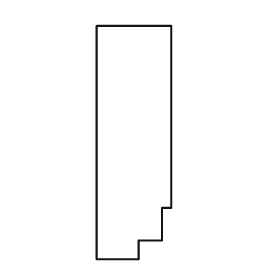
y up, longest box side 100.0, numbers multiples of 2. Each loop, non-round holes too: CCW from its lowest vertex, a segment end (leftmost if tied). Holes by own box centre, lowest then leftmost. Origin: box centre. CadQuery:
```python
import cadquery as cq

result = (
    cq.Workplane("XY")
    .moveTo(-16.0, -50.0)
    .lineTo(2.0, -50.0)
    .lineTo(2.0, -42.0)
    .lineTo(12.0, -42.0)
    .lineTo(12.0, -28.0)
    .lineTo(16.0, -28.0)
    .lineTo(16.0, 50.0)
    .lineTo(-16.0, 50.0)
    .close()
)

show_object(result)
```